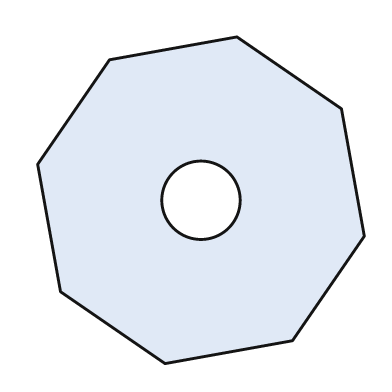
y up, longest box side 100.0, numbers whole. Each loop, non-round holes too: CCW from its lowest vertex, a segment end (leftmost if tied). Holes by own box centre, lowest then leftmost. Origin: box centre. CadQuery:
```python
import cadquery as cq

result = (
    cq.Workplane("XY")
    .moveTo(-11.0, -50.0)
    .lineTo(28.0, -43.0)
    .lineTo(50.0, -11.0)
    .lineTo(43.0, 28.0)
    .lineTo(11.0, 50.0)
    .lineTo(-28.0, 43.0)
    .lineTo(-50.0, 11.0)
    .lineTo(-43.0, -28.0)
    .close()
    .moveTo(0.0, 0.0)
    .circle(12.0)
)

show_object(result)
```